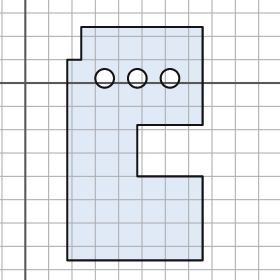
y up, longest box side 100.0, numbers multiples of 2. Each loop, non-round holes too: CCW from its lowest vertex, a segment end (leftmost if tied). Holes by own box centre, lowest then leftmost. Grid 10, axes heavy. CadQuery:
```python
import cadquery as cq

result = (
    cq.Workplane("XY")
    .moveTo(18.0, -76.0)
    .lineTo(76.0, -76.0)
    .lineTo(76.0, -40.0)
    .lineTo(48.0, -40.0)
    .lineTo(48.0, -18.0)
    .lineTo(76.0, -18.0)
    .lineTo(76.0, 24.0)
    .lineTo(24.0, 24.0)
    .lineTo(24.0, 10.0)
    .lineTo(18.0, 10.0)
    .close()
    .moveTo(34.0, 2.0)
    .circle(4.0)
    .moveTo(48.0, 2.0)
    .circle(4.0)
    .moveTo(62.0, 2.0)
    .circle(4.0)
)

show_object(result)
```